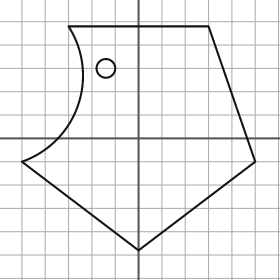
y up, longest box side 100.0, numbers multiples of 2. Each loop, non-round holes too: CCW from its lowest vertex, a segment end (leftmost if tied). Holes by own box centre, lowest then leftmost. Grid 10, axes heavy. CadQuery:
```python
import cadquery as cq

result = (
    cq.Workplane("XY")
    .moveTo(0.0, -48.0)
    .lineTo(50.0, -10.0)
    .lineTo(30.0, 48.0)
    .lineTo(-30.0, 48.0)
    .threePointArc((-26.0, 14.0), (-50.0, -10.0))
    .close()
    .moveTo(-14.0, 30.0)
    .circle(4.0)
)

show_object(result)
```